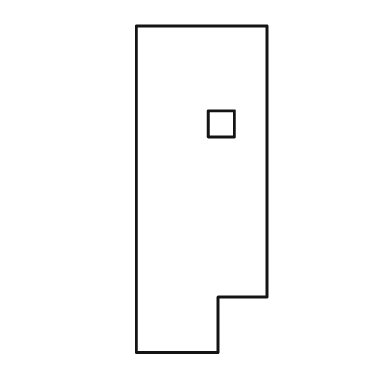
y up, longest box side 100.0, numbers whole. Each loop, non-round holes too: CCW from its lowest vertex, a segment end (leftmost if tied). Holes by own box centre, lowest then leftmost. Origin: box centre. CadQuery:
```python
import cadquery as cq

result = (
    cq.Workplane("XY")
    .moveTo(-20.0, -50.0)
    .lineTo(5.0, -50.0)
    .lineTo(5.0, -33.0)
    .lineTo(20.0, -33.0)
    .lineTo(20.0, 50.0)
    .lineTo(-20.0, 50.0)
    .close()
    .moveTo(2.0, 16.0)
    .lineTo(10.0, 16.0)
    .lineTo(10.0, 24.0)
    .lineTo(2.0, 24.0)
    .close()
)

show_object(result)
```